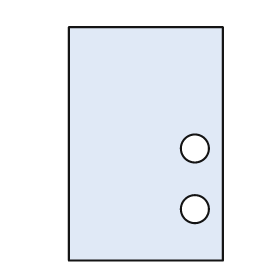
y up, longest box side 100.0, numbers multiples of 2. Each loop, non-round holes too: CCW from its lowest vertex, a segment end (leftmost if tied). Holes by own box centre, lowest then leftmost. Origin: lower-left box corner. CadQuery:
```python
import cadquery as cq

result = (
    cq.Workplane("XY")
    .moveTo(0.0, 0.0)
    .lineTo(66.0, 0.0)
    .lineTo(66.0, 100.0)
    .lineTo(0.0, 100.0)
    .close()
    .moveTo(54.0, 22.0)
    .circle(6.0)
    .moveTo(54.0, 48.0)
    .circle(6.0)
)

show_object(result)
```